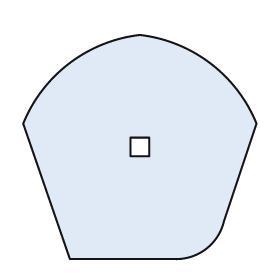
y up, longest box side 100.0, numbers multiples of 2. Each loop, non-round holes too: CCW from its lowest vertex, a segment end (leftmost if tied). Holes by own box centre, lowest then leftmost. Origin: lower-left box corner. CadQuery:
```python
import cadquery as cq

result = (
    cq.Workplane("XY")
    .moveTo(20.0, 0.0)
    .lineTo(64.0, 0.0)
    .threePointArc((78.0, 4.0), (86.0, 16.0))
    .lineTo(100.0, 58.0)
    .threePointArc((80.0, 84.0), (50.0, 96.0))
    .threePointArc((20.0, 84.0), (0.0, 58.0))
    .close()
    .moveTo(46.0, 44.0)
    .lineTo(54.0, 44.0)
    .lineTo(54.0, 52.0)
    .lineTo(46.0, 52.0)
    .close()
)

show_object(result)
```